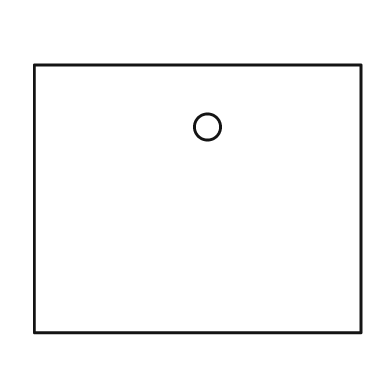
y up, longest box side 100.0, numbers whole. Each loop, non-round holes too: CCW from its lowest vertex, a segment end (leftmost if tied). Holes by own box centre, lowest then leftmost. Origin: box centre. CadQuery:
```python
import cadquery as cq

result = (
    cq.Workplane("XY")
    .moveTo(-50.0, -41.0)
    .lineTo(50.0, -41.0)
    .lineTo(50.0, 41.0)
    .lineTo(-50.0, 41.0)
    .close()
    .moveTo(3.0, 22.0)
    .circle(4.0)
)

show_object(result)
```